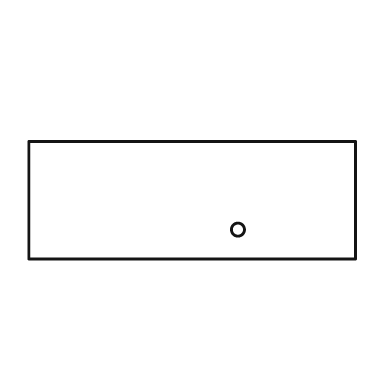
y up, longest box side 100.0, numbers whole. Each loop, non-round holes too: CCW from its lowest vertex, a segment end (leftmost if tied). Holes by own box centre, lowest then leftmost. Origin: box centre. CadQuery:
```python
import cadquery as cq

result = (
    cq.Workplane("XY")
    .moveTo(-50.0, -18.0)
    .lineTo(50.0, -18.0)
    .lineTo(50.0, 18.0)
    .lineTo(-50.0, 18.0)
    .close()
    .moveTo(14.0, -9.0)
    .circle(2.0)
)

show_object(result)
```